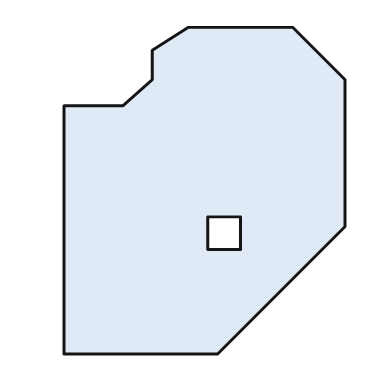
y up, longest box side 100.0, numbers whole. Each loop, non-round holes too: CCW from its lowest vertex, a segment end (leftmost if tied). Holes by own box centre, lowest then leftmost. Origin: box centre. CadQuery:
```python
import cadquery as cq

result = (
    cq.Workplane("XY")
    .moveTo(-43.0, -50.0)
    .lineTo(4.0, -50.0)
    .lineTo(43.0, -11.0)
    .lineTo(43.0, 34.0)
    .lineTo(27.0, 50.0)
    .lineTo(-5.0, 50.0)
    .lineTo(-16.0, 43.0)
    .lineTo(-16.0, 34.0)
    .lineTo(-25.0, 26.0)
    .lineTo(-43.0, 26.0)
    .close()
    .moveTo(1.0, -18.0)
    .lineTo(11.0, -18.0)
    .lineTo(11.0, -8.0)
    .lineTo(1.0, -8.0)
    .close()
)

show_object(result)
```